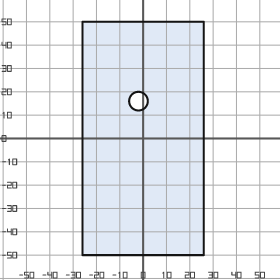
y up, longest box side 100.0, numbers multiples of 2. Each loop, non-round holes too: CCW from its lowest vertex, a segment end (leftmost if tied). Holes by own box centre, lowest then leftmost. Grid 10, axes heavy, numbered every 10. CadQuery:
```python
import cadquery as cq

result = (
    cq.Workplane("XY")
    .moveTo(-26.0, -50.0)
    .lineTo(26.0, -50.0)
    .lineTo(26.0, 50.0)
    .lineTo(-26.0, 50.0)
    .close()
    .moveTo(-2.0, 16.0)
    .circle(4.0)
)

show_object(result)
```